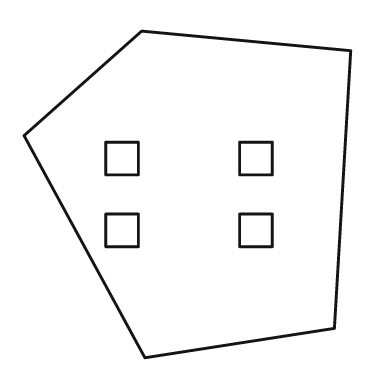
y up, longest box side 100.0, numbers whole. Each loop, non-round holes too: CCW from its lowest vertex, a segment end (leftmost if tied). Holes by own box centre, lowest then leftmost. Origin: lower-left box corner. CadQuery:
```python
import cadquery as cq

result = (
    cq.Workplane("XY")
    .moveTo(37.0, 0.0)
    .lineTo(95.0, 9.0)
    .lineTo(100.0, 94.0)
    .lineTo(36.0, 100.0)
    .lineTo(0.0, 68.0)
    .close()
    .moveTo(25.0, 34.0)
    .lineTo(35.0, 34.0)
    .lineTo(35.0, 44.0)
    .lineTo(25.0, 44.0)
    .close()
    .moveTo(66.0, 34.0)
    .lineTo(76.0, 34.0)
    .lineTo(76.0, 44.0)
    .lineTo(66.0, 44.0)
    .close()
    .moveTo(25.0, 56.0)
    .lineTo(35.0, 56.0)
    .lineTo(35.0, 66.0)
    .lineTo(25.0, 66.0)
    .close()
    .moveTo(66.0, 56.0)
    .lineTo(76.0, 56.0)
    .lineTo(76.0, 66.0)
    .lineTo(66.0, 66.0)
    .close()
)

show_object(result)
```